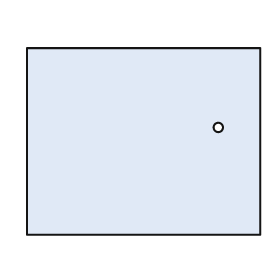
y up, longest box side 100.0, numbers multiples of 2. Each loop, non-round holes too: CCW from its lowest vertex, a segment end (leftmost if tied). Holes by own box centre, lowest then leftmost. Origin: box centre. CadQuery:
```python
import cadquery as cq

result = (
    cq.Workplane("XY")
    .moveTo(-50.0, -40.0)
    .lineTo(50.0, -40.0)
    .lineTo(50.0, 40.0)
    .lineTo(-50.0, 40.0)
    .close()
    .moveTo(32.0, 6.0)
    .circle(2.0)
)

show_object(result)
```